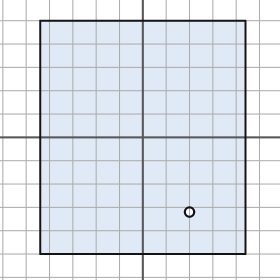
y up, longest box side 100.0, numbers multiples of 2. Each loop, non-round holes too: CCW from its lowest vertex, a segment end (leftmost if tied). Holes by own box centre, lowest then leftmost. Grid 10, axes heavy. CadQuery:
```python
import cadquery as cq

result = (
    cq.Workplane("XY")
    .moveTo(-44.0, -50.0)
    .lineTo(44.0, -50.0)
    .lineTo(44.0, 50.0)
    .lineTo(-44.0, 50.0)
    .close()
    .moveTo(20.0, -32.0)
    .circle(2.0)
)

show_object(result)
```